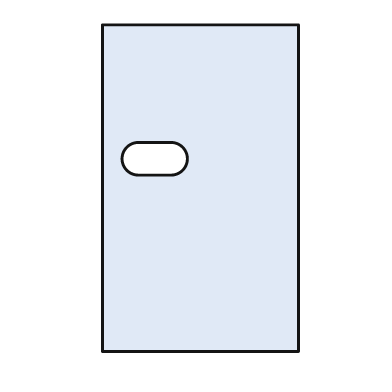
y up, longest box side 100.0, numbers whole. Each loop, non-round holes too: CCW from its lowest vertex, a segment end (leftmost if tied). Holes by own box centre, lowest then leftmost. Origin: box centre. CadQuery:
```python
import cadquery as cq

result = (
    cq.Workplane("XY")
    .moveTo(-30.0, -50.0)
    .lineTo(30.0, -50.0)
    .lineTo(30.0, 50.0)
    .lineTo(-30.0, 50.0)
    .close()
    .moveTo(-19.0, 4.0)
    .lineTo(-9.0, 4.0)
    .threePointArc((-4.0, 9.0), (-9.0, 14.0))
    .lineTo(-19.0, 14.0)
    .threePointArc((-24.0, 9.0), (-19.0, 4.0))
    .close()
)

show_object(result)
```